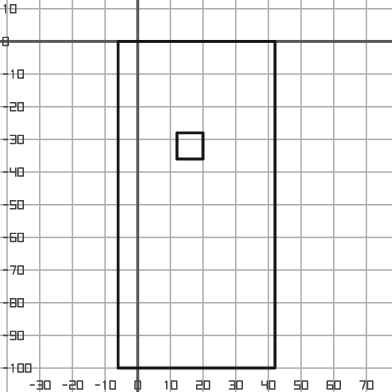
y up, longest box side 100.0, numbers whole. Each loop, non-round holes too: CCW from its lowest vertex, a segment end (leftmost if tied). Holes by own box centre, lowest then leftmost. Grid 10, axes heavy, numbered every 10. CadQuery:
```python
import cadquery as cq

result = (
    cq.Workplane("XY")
    .moveTo(-6.0, -100.0)
    .lineTo(42.0, -100.0)
    .lineTo(42.0, 0.0)
    .lineTo(-6.0, 0.0)
    .close()
    .moveTo(12.0, -36.0)
    .lineTo(20.0, -36.0)
    .lineTo(20.0, -28.0)
    .lineTo(12.0, -28.0)
    .close()
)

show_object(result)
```